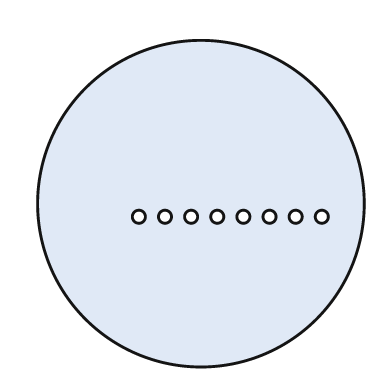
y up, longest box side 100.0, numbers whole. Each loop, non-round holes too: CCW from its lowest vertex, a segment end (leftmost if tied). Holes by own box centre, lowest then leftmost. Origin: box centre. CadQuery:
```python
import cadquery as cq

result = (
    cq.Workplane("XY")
    .moveTo(0.0, 0.0)
    .circle(50.0)
    .moveTo(-19.0, -4.0)
    .circle(2.0)
    .moveTo(-11.0, -4.0)
    .circle(2.0)
    .moveTo(-3.0, -4.0)
    .circle(2.0)
    .moveTo(5.0, -4.0)
    .circle(2.0)
    .moveTo(13.0, -4.0)
    .circle(2.0)
    .moveTo(21.0, -4.0)
    .circle(2.0)
    .moveTo(29.0, -4.0)
    .circle(2.0)
    .moveTo(37.0, -4.0)
    .circle(2.0)
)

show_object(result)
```